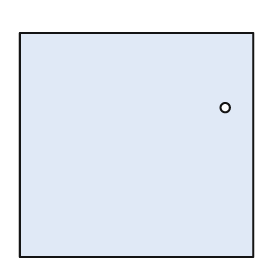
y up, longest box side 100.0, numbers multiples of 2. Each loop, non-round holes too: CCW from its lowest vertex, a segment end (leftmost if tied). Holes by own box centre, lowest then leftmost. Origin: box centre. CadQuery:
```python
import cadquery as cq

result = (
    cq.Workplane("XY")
    .moveTo(-50.0, -48.0)
    .lineTo(50.0, -48.0)
    .lineTo(50.0, 48.0)
    .lineTo(-50.0, 48.0)
    .close()
    .moveTo(38.0, 16.0)
    .circle(2.0)
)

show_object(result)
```